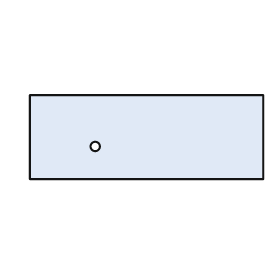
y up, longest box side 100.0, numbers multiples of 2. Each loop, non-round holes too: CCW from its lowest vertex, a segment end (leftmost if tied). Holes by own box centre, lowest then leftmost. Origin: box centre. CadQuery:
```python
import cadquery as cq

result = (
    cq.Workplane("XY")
    .moveTo(-50.0, -18.0)
    .lineTo(50.0, -18.0)
    .lineTo(50.0, 18.0)
    .lineTo(-50.0, 18.0)
    .close()
    .moveTo(-22.0, -4.0)
    .circle(2.0)
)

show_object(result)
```